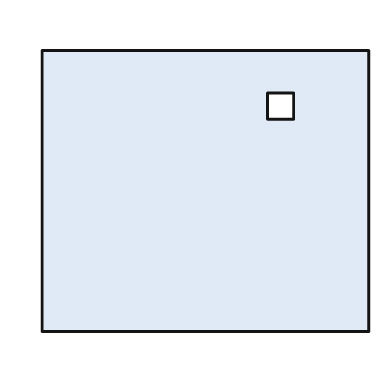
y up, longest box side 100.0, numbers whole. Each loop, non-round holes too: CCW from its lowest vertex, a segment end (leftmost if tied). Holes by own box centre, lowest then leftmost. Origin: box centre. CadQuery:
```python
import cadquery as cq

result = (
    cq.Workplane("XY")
    .moveTo(-50.0, -43.0)
    .lineTo(50.0, -43.0)
    .lineTo(50.0, 43.0)
    .lineTo(-50.0, 43.0)
    .close()
    .moveTo(19.0, 22.0)
    .lineTo(27.0, 22.0)
    .lineTo(27.0, 30.0)
    .lineTo(19.0, 30.0)
    .close()
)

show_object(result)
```